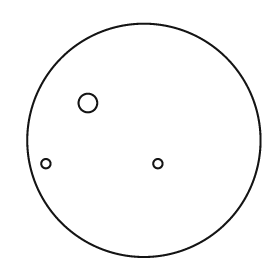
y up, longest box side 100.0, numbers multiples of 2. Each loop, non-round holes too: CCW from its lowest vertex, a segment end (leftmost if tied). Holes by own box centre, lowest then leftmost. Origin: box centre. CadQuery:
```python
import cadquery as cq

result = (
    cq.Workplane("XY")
    .moveTo(0.0, 0.0)
    .circle(50.0)
    .moveTo(-42.0, -10.0)
    .circle(2.0)
    .moveTo(6.0, -10.0)
    .circle(2.0)
    .moveTo(-24.0, 16.0)
    .circle(4.0)
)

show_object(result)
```